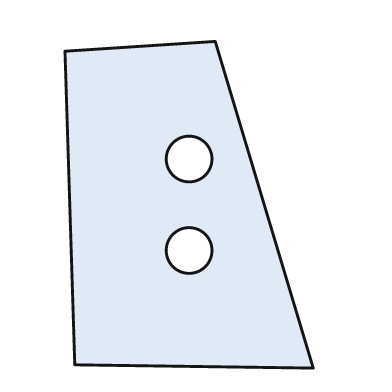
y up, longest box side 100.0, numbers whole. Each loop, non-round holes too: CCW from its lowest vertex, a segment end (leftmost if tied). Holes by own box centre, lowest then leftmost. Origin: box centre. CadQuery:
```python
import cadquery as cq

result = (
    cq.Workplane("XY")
    .moveTo(38.0, -50.0)
    .lineTo(8.0, 50.0)
    .lineTo(-38.0, 47.0)
    .lineTo(-35.0, -49.0)
    .close()
    .moveTo(0.0, -14.0)
    .circle(7.0)
    .moveTo(0.0, 14.0)
    .circle(7.0)
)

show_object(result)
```